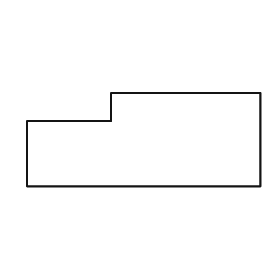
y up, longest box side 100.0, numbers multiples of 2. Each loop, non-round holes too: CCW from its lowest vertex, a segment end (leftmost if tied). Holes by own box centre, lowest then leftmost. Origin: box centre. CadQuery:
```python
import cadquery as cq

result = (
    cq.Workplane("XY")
    .moveTo(-50.0, -20.0)
    .lineTo(50.0, -20.0)
    .lineTo(50.0, 20.0)
    .lineTo(-14.0, 20.0)
    .lineTo(-14.0, 8.0)
    .lineTo(-50.0, 8.0)
    .close()
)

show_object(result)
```